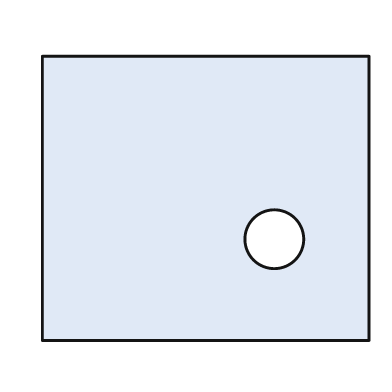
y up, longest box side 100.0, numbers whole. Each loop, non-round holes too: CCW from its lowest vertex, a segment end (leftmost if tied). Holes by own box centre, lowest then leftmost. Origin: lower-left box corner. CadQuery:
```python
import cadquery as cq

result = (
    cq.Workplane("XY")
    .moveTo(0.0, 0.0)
    .lineTo(100.0, 0.0)
    .lineTo(100.0, 87.0)
    .lineTo(0.0, 87.0)
    .close()
    .moveTo(71.0, 31.0)
    .circle(9.0)
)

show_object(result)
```